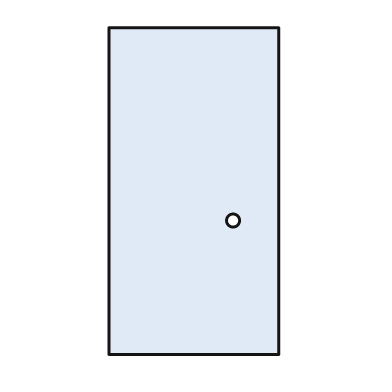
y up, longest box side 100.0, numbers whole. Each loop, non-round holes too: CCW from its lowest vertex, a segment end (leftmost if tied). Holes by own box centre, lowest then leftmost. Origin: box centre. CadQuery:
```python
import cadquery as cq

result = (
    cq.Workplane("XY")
    .moveTo(-26.0, -50.0)
    .lineTo(26.0, -50.0)
    .lineTo(26.0, 50.0)
    .lineTo(-26.0, 50.0)
    .close()
    .moveTo(12.0, -9.0)
    .circle(2.0)
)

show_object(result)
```